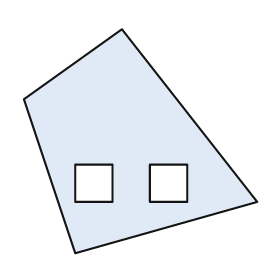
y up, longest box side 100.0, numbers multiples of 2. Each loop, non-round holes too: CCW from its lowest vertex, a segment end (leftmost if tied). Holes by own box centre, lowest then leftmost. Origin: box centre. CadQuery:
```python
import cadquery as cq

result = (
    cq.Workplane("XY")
    .moveTo(-28.0, -48.0)
    .lineTo(50.0, -26.0)
    .lineTo(-8.0, 48.0)
    .lineTo(-50.0, 18.0)
    .close()
    .moveTo(-28.0, -26.0)
    .lineTo(-12.0, -26.0)
    .lineTo(-12.0, -10.0)
    .lineTo(-28.0, -10.0)
    .close()
    .moveTo(4.0, -26.0)
    .lineTo(20.0, -26.0)
    .lineTo(20.0, -10.0)
    .lineTo(4.0, -10.0)
    .close()
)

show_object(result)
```